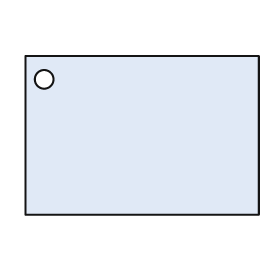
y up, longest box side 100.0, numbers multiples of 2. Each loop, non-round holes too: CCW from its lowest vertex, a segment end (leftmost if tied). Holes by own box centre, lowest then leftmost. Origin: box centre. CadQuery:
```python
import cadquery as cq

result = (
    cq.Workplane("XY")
    .moveTo(-50.0, -34.0)
    .lineTo(50.0, -34.0)
    .lineTo(50.0, 34.0)
    .lineTo(-50.0, 34.0)
    .close()
    .moveTo(-42.0, 24.0)
    .circle(4.0)
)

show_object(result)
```